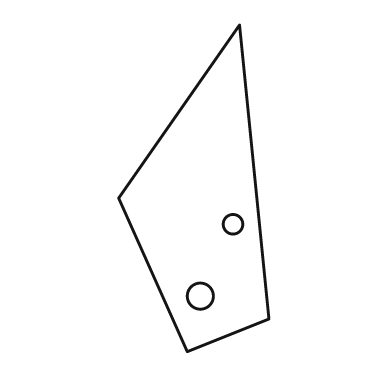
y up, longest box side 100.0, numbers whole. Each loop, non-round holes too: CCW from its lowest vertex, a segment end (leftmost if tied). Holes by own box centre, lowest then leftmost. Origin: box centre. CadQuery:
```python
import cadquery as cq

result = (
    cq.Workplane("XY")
    .moveTo(-2.0, -50.0)
    .lineTo(23.0, -40.0)
    .lineTo(14.0, 50.0)
    .lineTo(-23.0, -3.0)
    .close()
    .moveTo(2.0, -33.0)
    .circle(4.0)
    .moveTo(12.0, -11.0)
    .circle(3.0)
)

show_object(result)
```